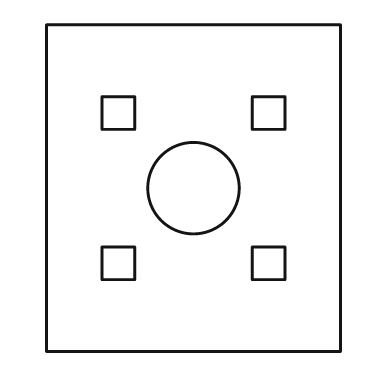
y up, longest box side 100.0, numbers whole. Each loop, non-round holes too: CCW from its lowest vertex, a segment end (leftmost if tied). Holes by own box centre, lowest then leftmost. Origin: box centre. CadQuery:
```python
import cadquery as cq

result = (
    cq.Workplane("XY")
    .moveTo(-45.0, -50.0)
    .lineTo(45.0, -50.0)
    .lineTo(45.0, 50.0)
    .lineTo(-45.0, 50.0)
    .close()
    .moveTo(-28.0, -28.0)
    .lineTo(-18.0, -28.0)
    .lineTo(-18.0, -18.0)
    .lineTo(-28.0, -18.0)
    .close()
    .moveTo(18.0, -28.0)
    .lineTo(28.0, -28.0)
    .lineTo(28.0, -18.0)
    .lineTo(18.0, -18.0)
    .close()
    .moveTo(0.0, 0.0)
    .circle(14.0)
    .moveTo(-28.0, 18.0)
    .lineTo(-18.0, 18.0)
    .lineTo(-18.0, 28.0)
    .lineTo(-28.0, 28.0)
    .close()
    .moveTo(18.0, 18.0)
    .lineTo(28.0, 18.0)
    .lineTo(28.0, 28.0)
    .lineTo(18.0, 28.0)
    .close()
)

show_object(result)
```